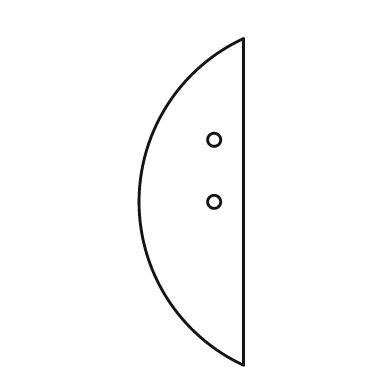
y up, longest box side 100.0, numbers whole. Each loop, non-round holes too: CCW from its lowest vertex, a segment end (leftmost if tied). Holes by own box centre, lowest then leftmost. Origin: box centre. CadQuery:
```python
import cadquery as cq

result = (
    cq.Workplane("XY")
    .moveTo(16.0, -50.0)
    .lineTo(16.0, 50.0)
    .threePointArc((-16.0, 0.0), (16.0, -50.0))
    .close()
    .moveTo(7.0, 0.0)
    .circle(2.0)
    .moveTo(7.0, 19.0)
    .circle(2.0)
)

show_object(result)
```